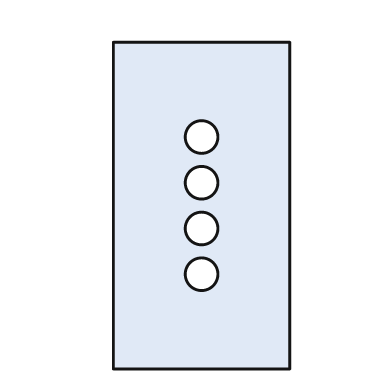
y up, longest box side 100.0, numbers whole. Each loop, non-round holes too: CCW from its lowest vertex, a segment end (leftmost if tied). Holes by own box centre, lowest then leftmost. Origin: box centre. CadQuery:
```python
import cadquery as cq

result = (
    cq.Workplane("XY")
    .moveTo(-27.0, -50.0)
    .lineTo(27.0, -50.0)
    .lineTo(27.0, 50.0)
    .lineTo(-27.0, 50.0)
    .close()
    .moveTo(0.0, -21.0)
    .circle(5.0)
    .moveTo(0.0, -7.0)
    .circle(5.0)
    .moveTo(0.0, 7.0)
    .circle(5.0)
    .moveTo(0.0, 21.0)
    .circle(5.0)
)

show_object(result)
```